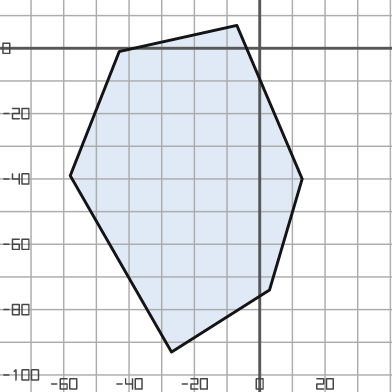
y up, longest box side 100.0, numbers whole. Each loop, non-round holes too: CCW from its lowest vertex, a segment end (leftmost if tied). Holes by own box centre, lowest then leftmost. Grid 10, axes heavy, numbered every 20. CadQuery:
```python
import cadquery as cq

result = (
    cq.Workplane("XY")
    .moveTo(-27.0, -93.0)
    .lineTo(3.0, -74.0)
    .lineTo(13.0, -40.0)
    .lineTo(-7.0, 7.0)
    .lineTo(-43.0, -1.0)
    .lineTo(-58.0, -39.0)
    .close()
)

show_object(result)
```